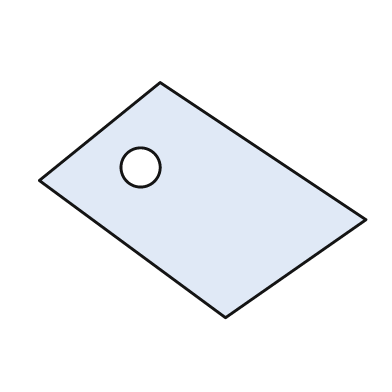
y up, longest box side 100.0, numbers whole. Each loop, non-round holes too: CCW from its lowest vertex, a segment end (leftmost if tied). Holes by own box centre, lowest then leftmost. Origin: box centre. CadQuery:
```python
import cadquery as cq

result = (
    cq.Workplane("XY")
    .moveTo(7.0, -36.0)
    .lineTo(50.0, -6.0)
    .lineTo(-13.0, 36.0)
    .lineTo(-50.0, 6.0)
    .close()
    .moveTo(-19.0, 10.0)
    .circle(6.0)
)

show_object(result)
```